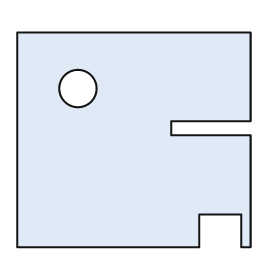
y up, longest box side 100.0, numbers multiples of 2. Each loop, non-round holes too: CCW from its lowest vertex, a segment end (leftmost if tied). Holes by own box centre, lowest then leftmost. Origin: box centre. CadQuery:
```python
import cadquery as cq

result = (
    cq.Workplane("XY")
    .moveTo(-50.0, -46.0)
    .lineTo(28.0, -46.0)
    .lineTo(28.0, -32.0)
    .lineTo(46.0, -32.0)
    .lineTo(46.0, -46.0)
    .lineTo(50.0, -46.0)
    .lineTo(50.0, 2.0)
    .lineTo(16.0, 2.0)
    .lineTo(16.0, 8.0)
    .lineTo(50.0, 8.0)
    .lineTo(50.0, 46.0)
    .lineTo(-50.0, 46.0)
    .close()
    .moveTo(-24.0, 22.0)
    .circle(8.0)
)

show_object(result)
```